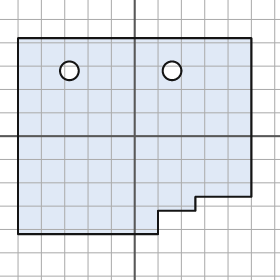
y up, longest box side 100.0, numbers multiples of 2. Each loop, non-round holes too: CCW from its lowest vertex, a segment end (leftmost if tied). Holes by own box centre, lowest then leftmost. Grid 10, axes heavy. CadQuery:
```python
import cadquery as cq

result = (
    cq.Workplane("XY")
    .moveTo(-50.0, -42.0)
    .lineTo(10.0, -42.0)
    .lineTo(10.0, -32.0)
    .lineTo(26.0, -32.0)
    .lineTo(26.0, -26.0)
    .lineTo(50.0, -26.0)
    .lineTo(50.0, 42.0)
    .lineTo(-50.0, 42.0)
    .close()
    .moveTo(-28.0, 28.0)
    .circle(4.0)
    .moveTo(16.0, 28.0)
    .circle(4.0)
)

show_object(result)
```